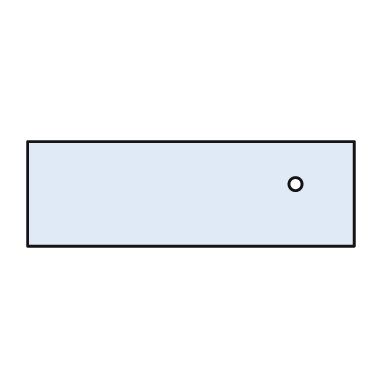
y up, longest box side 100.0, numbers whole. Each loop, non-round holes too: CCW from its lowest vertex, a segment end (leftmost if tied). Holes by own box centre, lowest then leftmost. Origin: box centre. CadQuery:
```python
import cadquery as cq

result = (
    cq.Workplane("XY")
    .moveTo(-50.0, -16.0)
    .lineTo(50.0, -16.0)
    .lineTo(50.0, 16.0)
    .lineTo(-50.0, 16.0)
    .close()
    .moveTo(32.0, 3.0)
    .circle(2.0)
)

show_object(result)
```